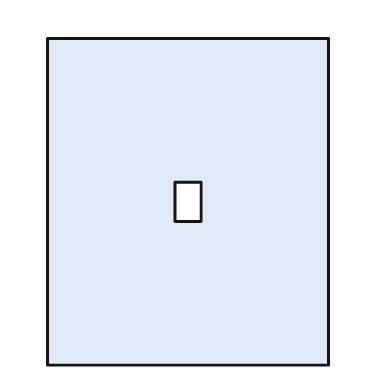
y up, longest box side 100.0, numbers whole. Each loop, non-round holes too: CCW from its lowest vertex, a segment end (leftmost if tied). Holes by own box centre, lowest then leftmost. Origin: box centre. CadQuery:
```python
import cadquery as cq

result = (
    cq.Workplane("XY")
    .moveTo(-43.0, -50.0)
    .lineTo(43.0, -50.0)
    .lineTo(43.0, 50.0)
    .lineTo(-43.0, 50.0)
    .close()
    .moveTo(-4.0, -6.0)
    .lineTo(4.0, -6.0)
    .lineTo(4.0, 6.0)
    .lineTo(-4.0, 6.0)
    .close()
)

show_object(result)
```